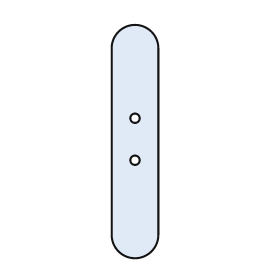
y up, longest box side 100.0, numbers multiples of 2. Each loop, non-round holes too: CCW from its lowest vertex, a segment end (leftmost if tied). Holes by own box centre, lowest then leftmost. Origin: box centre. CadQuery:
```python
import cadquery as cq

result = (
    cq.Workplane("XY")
    .moveTo(-10.0, -40.0)
    .threePointArc((0.0, -50.0), (10.0, -40.0))
    .lineTo(10.0, 40.0)
    .threePointArc((0.0, 50.0), (-10.0, 40.0))
    .close()
    .moveTo(0.0, -8.0)
    .circle(2.0)
    .moveTo(0.0, 10.0)
    .circle(2.0)
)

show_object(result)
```